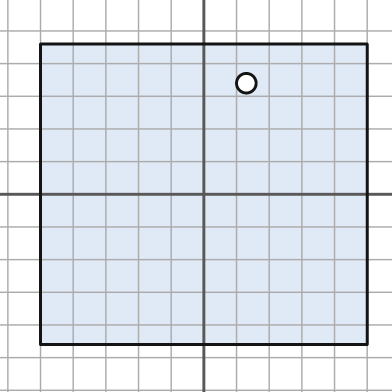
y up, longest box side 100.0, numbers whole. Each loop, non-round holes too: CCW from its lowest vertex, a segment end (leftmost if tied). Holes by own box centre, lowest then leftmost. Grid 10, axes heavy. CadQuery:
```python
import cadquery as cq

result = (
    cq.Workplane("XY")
    .moveTo(-50.0, -46.0)
    .lineTo(50.0, -46.0)
    .lineTo(50.0, 46.0)
    .lineTo(-50.0, 46.0)
    .close()
    .moveTo(13.0, 34.0)
    .circle(3.0)
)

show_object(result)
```